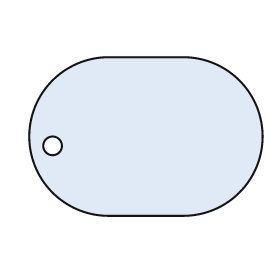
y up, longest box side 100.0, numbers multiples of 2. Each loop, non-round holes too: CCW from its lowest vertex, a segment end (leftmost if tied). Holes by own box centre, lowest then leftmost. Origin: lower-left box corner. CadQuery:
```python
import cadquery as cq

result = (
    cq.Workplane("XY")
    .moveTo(34.0, 0.0)
    .lineTo(66.0, 0.0)
    .threePointArc((100.0, 34.0), (66.0, 68.0))
    .lineTo(34.0, 68.0)
    .threePointArc((0.0, 34.0), (34.0, 0.0))
    .close()
    .moveTo(10.0, 30.0)
    .circle(4.0)
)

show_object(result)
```